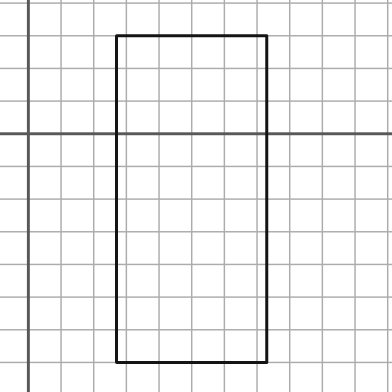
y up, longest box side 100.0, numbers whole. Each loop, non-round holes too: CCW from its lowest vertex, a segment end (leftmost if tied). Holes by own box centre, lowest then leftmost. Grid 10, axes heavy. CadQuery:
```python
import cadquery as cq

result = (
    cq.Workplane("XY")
    .moveTo(27.0, -70.0)
    .lineTo(73.0, -70.0)
    .lineTo(73.0, 30.0)
    .lineTo(27.0, 30.0)
    .close()
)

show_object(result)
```